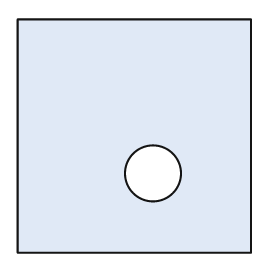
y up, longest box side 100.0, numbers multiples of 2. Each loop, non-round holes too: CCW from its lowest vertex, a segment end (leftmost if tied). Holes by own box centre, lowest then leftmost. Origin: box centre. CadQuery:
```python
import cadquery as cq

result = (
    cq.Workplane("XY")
    .moveTo(-50.0, -50.0)
    .lineTo(50.0, -50.0)
    .lineTo(50.0, 50.0)
    .lineTo(-50.0, 50.0)
    .close()
    .moveTo(8.0, -16.0)
    .circle(12.0)
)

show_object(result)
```